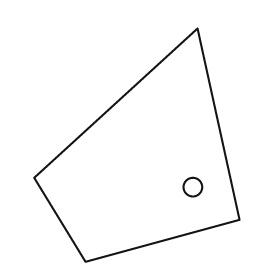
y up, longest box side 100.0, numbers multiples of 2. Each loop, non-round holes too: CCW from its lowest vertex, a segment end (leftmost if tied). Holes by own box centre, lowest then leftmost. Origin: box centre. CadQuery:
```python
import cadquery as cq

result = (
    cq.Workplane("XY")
    .moveTo(-22.0, -50.0)
    .lineTo(44.0, -32.0)
    .lineTo(26.0, 50.0)
    .lineTo(-44.0, -14.0)
    .close()
    .moveTo(24.0, -18.0)
    .circle(4.0)
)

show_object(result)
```